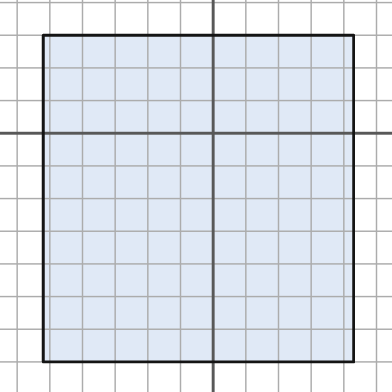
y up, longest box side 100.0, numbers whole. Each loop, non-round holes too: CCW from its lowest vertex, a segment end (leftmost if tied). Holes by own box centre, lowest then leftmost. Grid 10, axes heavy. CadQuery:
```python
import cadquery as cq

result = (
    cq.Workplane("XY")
    .moveTo(-52.0, -70.0)
    .lineTo(43.0, -70.0)
    .lineTo(43.0, 30.0)
    .lineTo(-52.0, 30.0)
    .close()
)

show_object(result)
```